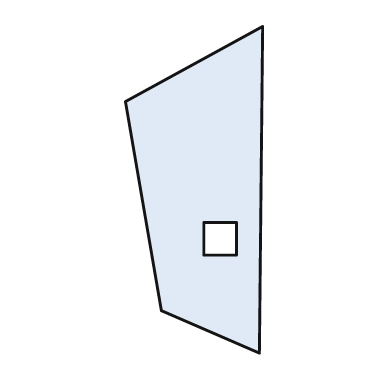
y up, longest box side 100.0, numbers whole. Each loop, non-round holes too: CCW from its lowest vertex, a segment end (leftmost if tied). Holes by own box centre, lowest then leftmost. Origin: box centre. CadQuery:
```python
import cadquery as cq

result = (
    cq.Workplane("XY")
    .moveTo(20.0, -50.0)
    .lineTo(21.0, 50.0)
    .lineTo(-21.0, 27.0)
    .lineTo(-10.0, -37.0)
    .close()
    .moveTo(3.0, -20.0)
    .lineTo(13.0, -20.0)
    .lineTo(13.0, -10.0)
    .lineTo(3.0, -10.0)
    .close()
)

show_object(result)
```